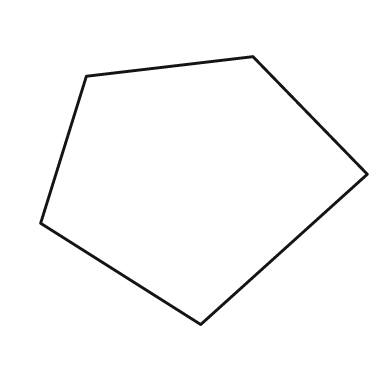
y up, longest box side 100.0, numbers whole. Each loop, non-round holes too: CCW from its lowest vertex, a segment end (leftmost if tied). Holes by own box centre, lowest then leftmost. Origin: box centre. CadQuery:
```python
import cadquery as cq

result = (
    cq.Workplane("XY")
    .moveTo(-1.0, -41.0)
    .lineTo(50.0, 5.0)
    .lineTo(15.0, 41.0)
    .lineTo(-36.0, 35.0)
    .lineTo(-50.0, -10.0)
    .close()
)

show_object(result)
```